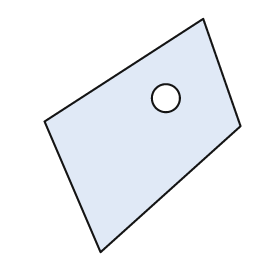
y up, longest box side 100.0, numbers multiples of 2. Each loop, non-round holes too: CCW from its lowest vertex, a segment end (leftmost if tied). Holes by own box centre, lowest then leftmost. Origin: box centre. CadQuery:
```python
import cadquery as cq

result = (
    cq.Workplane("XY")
    .moveTo(-18.0, -50.0)
    .lineTo(42.0, 4.0)
    .lineTo(26.0, 50.0)
    .lineTo(-42.0, 6.0)
    .close()
    .moveTo(10.0, 16.0)
    .circle(6.0)
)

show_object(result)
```